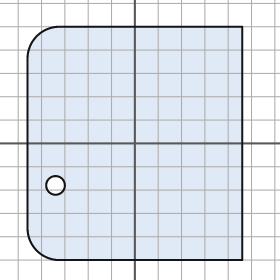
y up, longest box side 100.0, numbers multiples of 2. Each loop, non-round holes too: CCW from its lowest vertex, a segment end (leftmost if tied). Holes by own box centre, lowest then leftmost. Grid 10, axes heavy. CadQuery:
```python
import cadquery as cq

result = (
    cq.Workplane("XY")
    .moveTo(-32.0, -50.0)
    .lineTo(46.0, -50.0)
    .lineTo(46.0, 50.0)
    .lineTo(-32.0, 50.0)
    .threePointArc((-42.0, 46.0), (-46.0, 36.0))
    .lineTo(-46.0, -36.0)
    .threePointArc((-42.0, -46.0), (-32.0, -50.0))
    .close()
    .moveTo(-34.0, -18.0)
    .circle(4.0)
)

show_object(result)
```